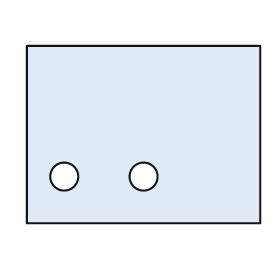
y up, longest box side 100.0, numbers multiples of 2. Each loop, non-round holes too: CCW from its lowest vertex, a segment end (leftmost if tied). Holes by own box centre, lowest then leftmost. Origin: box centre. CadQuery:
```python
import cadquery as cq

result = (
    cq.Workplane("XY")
    .moveTo(-50.0, -38.0)
    .lineTo(50.0, -38.0)
    .lineTo(50.0, 38.0)
    .lineTo(-50.0, 38.0)
    .close()
    .moveTo(-34.0, -18.0)
    .circle(6.0)
    .moveTo(0.0, -18.0)
    .circle(6.0)
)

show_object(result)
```